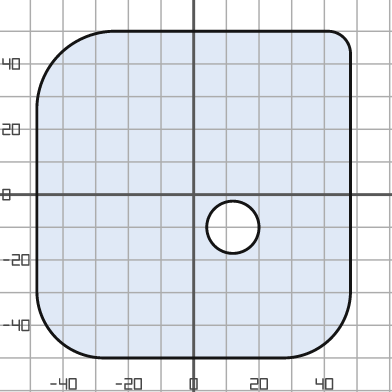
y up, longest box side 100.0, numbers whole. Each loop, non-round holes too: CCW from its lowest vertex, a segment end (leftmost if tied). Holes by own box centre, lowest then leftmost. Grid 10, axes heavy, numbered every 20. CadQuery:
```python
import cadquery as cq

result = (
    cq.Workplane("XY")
    .moveTo(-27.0, -50.0)
    .lineTo(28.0, -50.0)
    .threePointArc((42.0, -44.0), (48.0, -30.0))
    .lineTo(48.0, 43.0)
    .threePointArc((46.0, 48.0), (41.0, 50.0))
    .lineTo(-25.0, 50.0)
    .threePointArc((-41.0, 43.0), (-48.0, 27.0))
    .lineTo(-48.0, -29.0)
    .threePointArc((-42.0, -44.0), (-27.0, -50.0))
    .close()
    .moveTo(12.0, -10.0)
    .circle(8.0)
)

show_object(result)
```